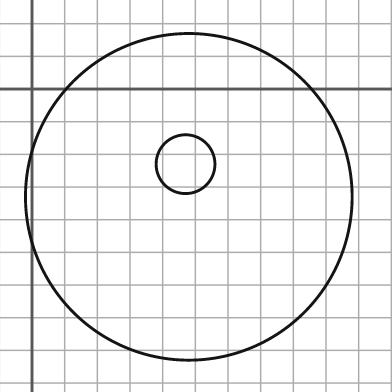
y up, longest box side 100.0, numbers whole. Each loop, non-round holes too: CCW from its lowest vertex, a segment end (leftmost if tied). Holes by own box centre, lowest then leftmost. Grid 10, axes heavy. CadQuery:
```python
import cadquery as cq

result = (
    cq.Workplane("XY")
    .moveTo(48.0, -33.0)
    .circle(50.0)
    .moveTo(47.0, -23.0)
    .circle(9.0)
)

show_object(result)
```